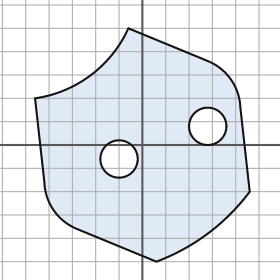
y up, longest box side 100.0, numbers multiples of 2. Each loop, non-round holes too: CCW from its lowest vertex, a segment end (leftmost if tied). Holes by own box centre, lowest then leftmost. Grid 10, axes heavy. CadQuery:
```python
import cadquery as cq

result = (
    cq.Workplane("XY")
    .moveTo(6.0, -50.0)
    .threePointArc((28.0, -38.0), (46.0, -20.0))
    .lineTo(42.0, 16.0)
    .threePointArc((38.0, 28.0), (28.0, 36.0))
    .lineTo(-6.0, 50.0)
    .threePointArc((-22.0, 30.0), (-46.0, 20.0))
    .lineTo(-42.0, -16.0)
    .threePointArc((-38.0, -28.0), (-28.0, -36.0))
    .close()
    .moveTo(-10.0, -6.0)
    .circle(8.0)
    .moveTo(28.0, 8.0)
    .circle(8.0)
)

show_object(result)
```